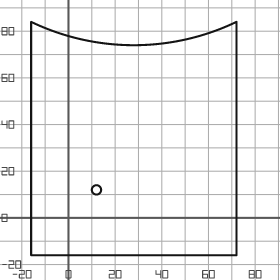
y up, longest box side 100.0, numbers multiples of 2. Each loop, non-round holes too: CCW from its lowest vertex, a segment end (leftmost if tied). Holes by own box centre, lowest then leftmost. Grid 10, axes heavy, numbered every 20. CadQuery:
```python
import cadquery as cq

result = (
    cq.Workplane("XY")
    .moveTo(-16.0, -16.0)
    .lineTo(72.0, -16.0)
    .lineTo(72.0, 84.0)
    .threePointArc((28.0, 74.0), (-16.0, 84.0))
    .close()
    .moveTo(12.0, 12.0)
    .circle(2.0)
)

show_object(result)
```